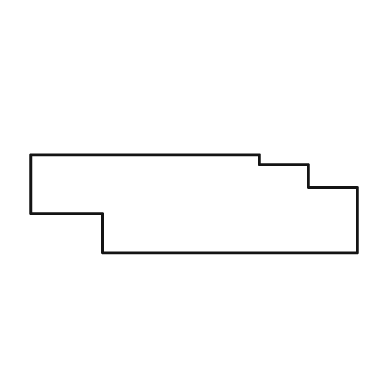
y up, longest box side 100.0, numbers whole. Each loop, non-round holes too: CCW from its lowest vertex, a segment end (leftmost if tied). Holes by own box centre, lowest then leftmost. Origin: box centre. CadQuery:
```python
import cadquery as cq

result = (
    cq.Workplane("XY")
    .moveTo(-28.0, -15.0)
    .lineTo(50.0, -15.0)
    .lineTo(50.0, 5.0)
    .lineTo(35.0, 5.0)
    .lineTo(35.0, 12.0)
    .lineTo(20.0, 12.0)
    .lineTo(20.0, 15.0)
    .lineTo(-50.0, 15.0)
    .lineTo(-50.0, -3.0)
    .lineTo(-28.0, -3.0)
    .close()
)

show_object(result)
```